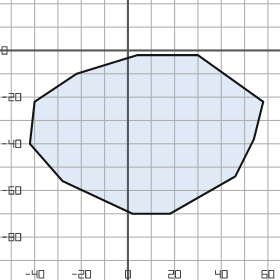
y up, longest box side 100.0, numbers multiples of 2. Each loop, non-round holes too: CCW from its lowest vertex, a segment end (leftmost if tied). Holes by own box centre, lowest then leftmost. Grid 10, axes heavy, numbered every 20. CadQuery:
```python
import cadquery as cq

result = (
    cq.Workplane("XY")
    .moveTo(2.0, -70.0)
    .lineTo(18.0, -70.0)
    .lineTo(46.0, -54.0)
    .lineTo(54.0, -38.0)
    .lineTo(58.0, -22.0)
    .lineTo(30.0, -2.0)
    .lineTo(4.0, -2.0)
    .lineTo(-22.0, -10.0)
    .lineTo(-40.0, -22.0)
    .lineTo(-42.0, -40.0)
    .lineTo(-28.0, -56.0)
    .close()
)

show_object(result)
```